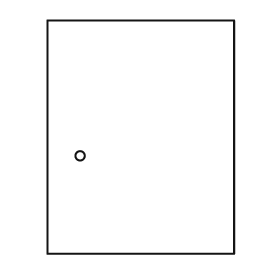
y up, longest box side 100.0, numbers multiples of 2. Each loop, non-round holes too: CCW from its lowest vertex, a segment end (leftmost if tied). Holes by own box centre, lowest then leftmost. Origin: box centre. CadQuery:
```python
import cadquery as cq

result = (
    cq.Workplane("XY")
    .moveTo(-40.0, -50.0)
    .lineTo(40.0, -50.0)
    .lineTo(40.0, 50.0)
    .lineTo(-40.0, 50.0)
    .close()
    .moveTo(-26.0, -8.0)
    .circle(2.0)
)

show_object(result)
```